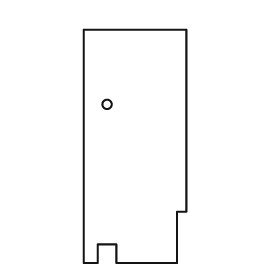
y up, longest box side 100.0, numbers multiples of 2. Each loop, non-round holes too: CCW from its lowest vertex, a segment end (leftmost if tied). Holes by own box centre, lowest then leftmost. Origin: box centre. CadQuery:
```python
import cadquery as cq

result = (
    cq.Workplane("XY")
    .moveTo(-22.0, -50.0)
    .lineTo(-16.0, -50.0)
    .lineTo(-16.0, -42.0)
    .lineTo(-8.0, -42.0)
    .lineTo(-8.0, -50.0)
    .lineTo(18.0, -50.0)
    .lineTo(18.0, -28.0)
    .lineTo(22.0, -28.0)
    .lineTo(22.0, 50.0)
    .lineTo(-22.0, 50.0)
    .close()
    .moveTo(-12.0, 18.0)
    .circle(2.0)
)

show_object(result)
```